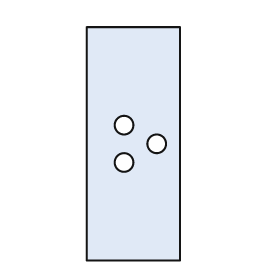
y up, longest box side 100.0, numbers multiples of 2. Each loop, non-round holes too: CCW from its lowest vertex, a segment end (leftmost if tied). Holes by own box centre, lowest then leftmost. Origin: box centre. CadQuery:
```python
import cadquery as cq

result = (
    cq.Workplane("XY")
    .moveTo(-20.0, -50.0)
    .lineTo(20.0, -50.0)
    .lineTo(20.0, 50.0)
    .lineTo(-20.0, 50.0)
    .close()
    .moveTo(-4.0, -8.0)
    .circle(4.0)
    .moveTo(10.0, 0.0)
    .circle(4.0)
    .moveTo(-4.0, 8.0)
    .circle(4.0)
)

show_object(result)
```